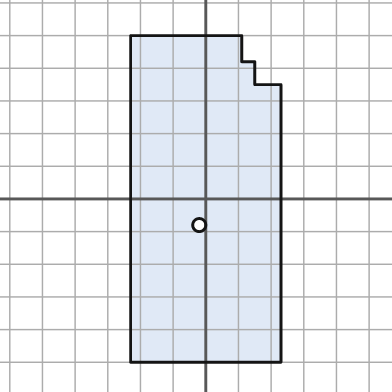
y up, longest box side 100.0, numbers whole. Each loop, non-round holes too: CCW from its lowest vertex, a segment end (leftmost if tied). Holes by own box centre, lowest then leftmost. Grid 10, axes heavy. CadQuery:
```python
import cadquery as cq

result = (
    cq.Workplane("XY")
    .moveTo(-23.0, -50.0)
    .lineTo(23.0, -50.0)
    .lineTo(23.0, 35.0)
    .lineTo(15.0, 35.0)
    .lineTo(15.0, 42.0)
    .lineTo(11.0, 42.0)
    .lineTo(11.0, 50.0)
    .lineTo(-23.0, 50.0)
    .close()
    .moveTo(-2.0, -8.0)
    .circle(2.0)
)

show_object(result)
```